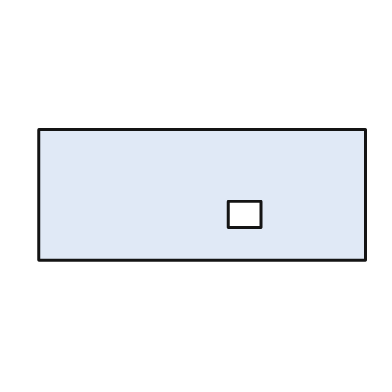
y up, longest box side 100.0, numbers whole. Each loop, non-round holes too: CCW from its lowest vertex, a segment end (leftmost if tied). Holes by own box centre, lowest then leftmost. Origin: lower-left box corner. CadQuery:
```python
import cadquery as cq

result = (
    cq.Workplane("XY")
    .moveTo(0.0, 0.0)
    .lineTo(100.0, 0.0)
    .lineTo(100.0, 40.0)
    .lineTo(0.0, 40.0)
    .close()
    .moveTo(58.0, 10.0)
    .lineTo(68.0, 10.0)
    .lineTo(68.0, 18.0)
    .lineTo(58.0, 18.0)
    .close()
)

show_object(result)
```